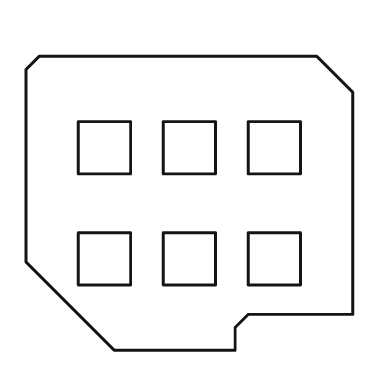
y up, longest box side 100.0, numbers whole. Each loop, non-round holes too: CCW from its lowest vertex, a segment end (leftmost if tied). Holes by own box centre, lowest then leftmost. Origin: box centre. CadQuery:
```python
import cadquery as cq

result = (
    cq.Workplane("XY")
    .moveTo(-23.0, -45.0)
    .lineTo(14.0, -45.0)
    .lineTo(14.0, -38.0)
    .lineTo(18.0, -34.0)
    .lineTo(50.0, -34.0)
    .lineTo(50.0, 34.0)
    .lineTo(39.0, 45.0)
    .lineTo(-46.0, 45.0)
    .lineTo(-50.0, 41.0)
    .lineTo(-50.0, -18.0)
    .close()
    .moveTo(-34.0, -25.0)
    .lineTo(-18.0, -25.0)
    .lineTo(-18.0, -9.0)
    .lineTo(-34.0, -9.0)
    .close()
    .moveTo(-8.0, -25.0)
    .lineTo(8.0, -25.0)
    .lineTo(8.0, -9.0)
    .lineTo(-8.0, -9.0)
    .close()
    .moveTo(18.0, -25.0)
    .lineTo(34.0, -25.0)
    .lineTo(34.0, -9.0)
    .lineTo(18.0, -9.0)
    .close()
    .moveTo(-34.0, 9.0)
    .lineTo(-18.0, 9.0)
    .lineTo(-18.0, 25.0)
    .lineTo(-34.0, 25.0)
    .close()
    .moveTo(-8.0, 9.0)
    .lineTo(8.0, 9.0)
    .lineTo(8.0, 25.0)
    .lineTo(-8.0, 25.0)
    .close()
    .moveTo(18.0, 9.0)
    .lineTo(34.0, 9.0)
    .lineTo(34.0, 25.0)
    .lineTo(18.0, 25.0)
    .close()
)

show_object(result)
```